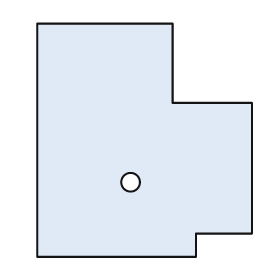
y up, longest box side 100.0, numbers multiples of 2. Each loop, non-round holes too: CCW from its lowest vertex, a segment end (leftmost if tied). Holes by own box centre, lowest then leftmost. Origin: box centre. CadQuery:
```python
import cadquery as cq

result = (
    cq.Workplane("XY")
    .moveTo(-46.0, -50.0)
    .lineTo(22.0, -50.0)
    .lineTo(22.0, -40.0)
    .lineTo(46.0, -40.0)
    .lineTo(46.0, 16.0)
    .lineTo(12.0, 16.0)
    .lineTo(12.0, 50.0)
    .lineTo(-46.0, 50.0)
    .close()
    .moveTo(-6.0, -18.0)
    .circle(4.0)
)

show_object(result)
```